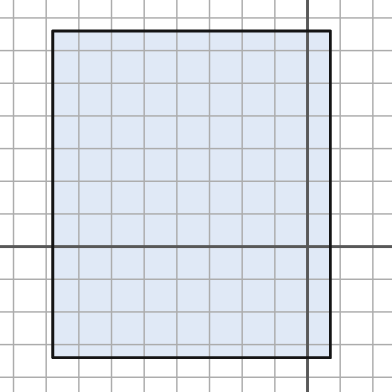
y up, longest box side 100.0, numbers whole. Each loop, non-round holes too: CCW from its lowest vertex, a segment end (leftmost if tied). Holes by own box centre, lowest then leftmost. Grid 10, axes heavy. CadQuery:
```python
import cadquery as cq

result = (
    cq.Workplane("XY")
    .moveTo(-78.0, -34.0)
    .lineTo(7.0, -34.0)
    .lineTo(7.0, 66.0)
    .lineTo(-78.0, 66.0)
    .close()
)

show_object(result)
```